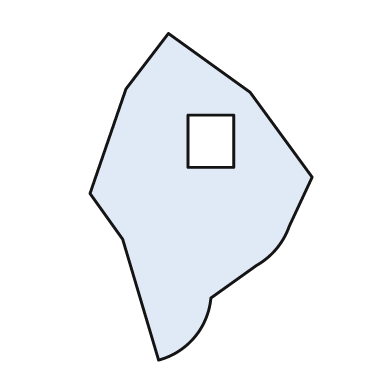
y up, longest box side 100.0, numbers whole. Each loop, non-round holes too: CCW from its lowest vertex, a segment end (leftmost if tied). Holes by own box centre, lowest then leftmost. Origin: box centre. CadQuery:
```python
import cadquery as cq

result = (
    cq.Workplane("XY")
    .moveTo(-13.0, -50.0)
    .threePointArc((-2.0, -43.0), (3.0, -31.0))
    .lineTo(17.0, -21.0)
    .threePointArc((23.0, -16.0), (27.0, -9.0))
    .lineTo(34.0, 6.0)
    .lineTo(15.0, 32.0)
    .lineTo(-10.0, 50.0)
    .lineTo(-23.0, 33.0)
    .lineTo(-34.0, 1.0)
    .lineTo(-24.0, -13.0)
    .close()
    .moveTo(-4.0, 9.0)
    .lineTo(10.0, 9.0)
    .lineTo(10.0, 25.0)
    .lineTo(-4.0, 25.0)
    .close()
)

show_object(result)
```